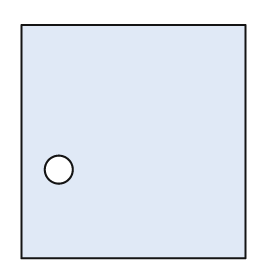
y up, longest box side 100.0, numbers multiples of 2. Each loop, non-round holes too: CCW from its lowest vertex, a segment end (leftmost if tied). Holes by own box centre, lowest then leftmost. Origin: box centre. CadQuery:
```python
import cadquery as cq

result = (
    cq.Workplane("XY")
    .moveTo(-48.0, -50.0)
    .lineTo(48.0, -50.0)
    .lineTo(48.0, 50.0)
    .lineTo(-48.0, 50.0)
    .close()
    .moveTo(-32.0, -12.0)
    .circle(6.0)
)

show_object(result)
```